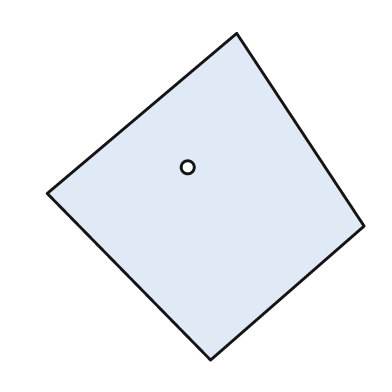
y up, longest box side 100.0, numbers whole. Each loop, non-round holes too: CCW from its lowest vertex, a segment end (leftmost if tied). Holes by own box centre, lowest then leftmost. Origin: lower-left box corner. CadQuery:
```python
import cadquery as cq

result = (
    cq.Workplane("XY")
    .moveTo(50.0, 0.0)
    .lineTo(97.0, 41.0)
    .lineTo(58.0, 100.0)
    .lineTo(0.0, 51.0)
    .close()
    .moveTo(43.0, 59.0)
    .circle(2.0)
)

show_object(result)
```